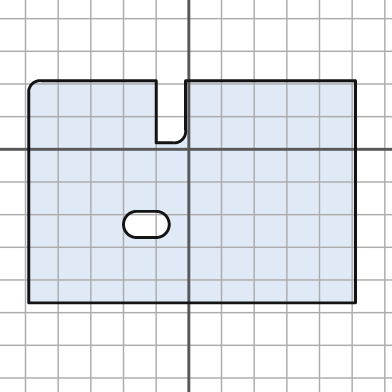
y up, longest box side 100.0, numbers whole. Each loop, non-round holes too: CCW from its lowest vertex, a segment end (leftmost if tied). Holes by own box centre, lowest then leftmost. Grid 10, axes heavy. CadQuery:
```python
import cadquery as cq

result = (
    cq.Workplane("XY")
    .moveTo(-49.0, -47.0)
    .lineTo(51.0, -47.0)
    .lineTo(51.0, 21.0)
    .lineTo(-1.0, 21.0)
    .lineTo(-1.0, 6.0)
    .threePointArc((-2.0, 3.0), (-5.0, 2.0))
    .lineTo(-10.0, 2.0)
    .lineTo(-10.0, 21.0)
    .lineTo(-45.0, 21.0)
    .threePointArc((-48.0, 20.0), (-49.0, 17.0))
    .close()
    .moveTo(-16.0, -27.0)
    .lineTo(-10.0, -27.0)
    .threePointArc((-6.0, -23.0), (-10.0, -19.0))
    .lineTo(-16.0, -19.0)
    .threePointArc((-20.0, -23.0), (-16.0, -27.0))
    .close()
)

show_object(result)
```